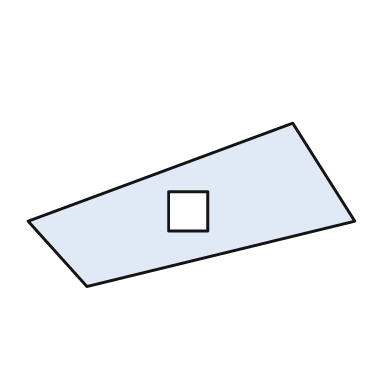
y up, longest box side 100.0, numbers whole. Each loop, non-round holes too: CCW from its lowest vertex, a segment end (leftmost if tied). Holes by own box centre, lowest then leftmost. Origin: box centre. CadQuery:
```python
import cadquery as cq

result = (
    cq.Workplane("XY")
    .moveTo(-32.0, -25.0)
    .lineTo(50.0, -5.0)
    .lineTo(31.0, 25.0)
    .lineTo(-50.0, -5.0)
    .close()
    .moveTo(-7.0, -8.0)
    .lineTo(5.0, -8.0)
    .lineTo(5.0, 4.0)
    .lineTo(-7.0, 4.0)
    .close()
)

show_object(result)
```